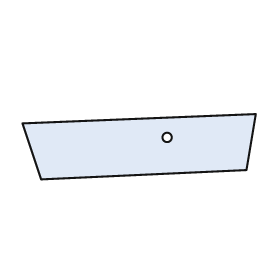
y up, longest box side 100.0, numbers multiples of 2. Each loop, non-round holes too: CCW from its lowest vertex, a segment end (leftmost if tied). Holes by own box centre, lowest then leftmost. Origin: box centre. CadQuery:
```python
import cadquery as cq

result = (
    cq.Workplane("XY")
    .moveTo(-42.0, -14.0)
    .lineTo(46.0, -10.0)
    .lineTo(50.0, 14.0)
    .lineTo(-50.0, 10.0)
    .close()
    .moveTo(12.0, 4.0)
    .circle(2.0)
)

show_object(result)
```